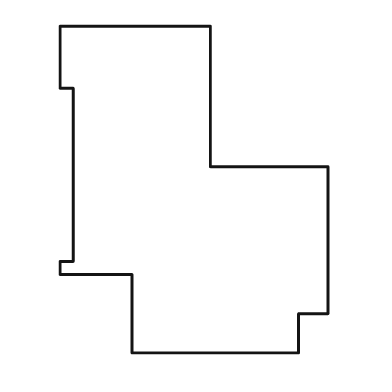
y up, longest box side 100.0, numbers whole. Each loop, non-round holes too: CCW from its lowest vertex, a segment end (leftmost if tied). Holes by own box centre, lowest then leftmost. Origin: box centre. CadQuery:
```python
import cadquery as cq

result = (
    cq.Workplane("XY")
    .moveTo(-19.0, -50.0)
    .lineTo(32.0, -50.0)
    .lineTo(32.0, -38.0)
    .lineTo(41.0, -38.0)
    .lineTo(41.0, 7.0)
    .lineTo(5.0, 7.0)
    .lineTo(5.0, 50.0)
    .lineTo(-41.0, 50.0)
    .lineTo(-41.0, 31.0)
    .lineTo(-37.0, 31.0)
    .lineTo(-37.0, -22.0)
    .lineTo(-41.0, -22.0)
    .lineTo(-41.0, -26.0)
    .lineTo(-19.0, -26.0)
    .close()
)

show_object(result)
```